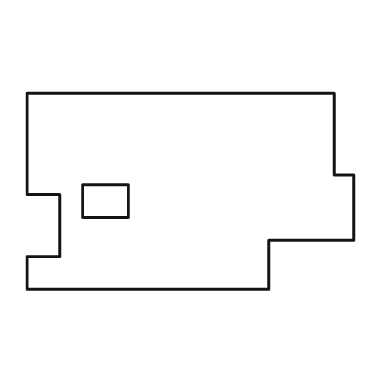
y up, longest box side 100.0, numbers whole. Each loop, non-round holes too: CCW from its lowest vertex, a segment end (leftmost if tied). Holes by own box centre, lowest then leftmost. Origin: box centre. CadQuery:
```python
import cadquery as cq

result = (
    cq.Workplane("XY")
    .moveTo(-50.0, -30.0)
    .lineTo(24.0, -30.0)
    .lineTo(24.0, -15.0)
    .lineTo(50.0, -15.0)
    .lineTo(50.0, 5.0)
    .lineTo(44.0, 5.0)
    .lineTo(44.0, 30.0)
    .lineTo(-50.0, 30.0)
    .lineTo(-50.0, -1.0)
    .lineTo(-40.0, -1.0)
    .lineTo(-40.0, -20.0)
    .lineTo(-50.0, -20.0)
    .close()
    .moveTo(-33.0, -8.0)
    .lineTo(-19.0, -8.0)
    .lineTo(-19.0, 2.0)
    .lineTo(-33.0, 2.0)
    .close()
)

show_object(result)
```